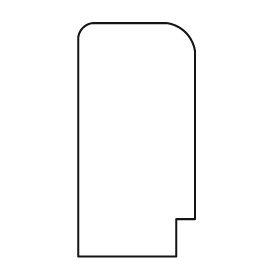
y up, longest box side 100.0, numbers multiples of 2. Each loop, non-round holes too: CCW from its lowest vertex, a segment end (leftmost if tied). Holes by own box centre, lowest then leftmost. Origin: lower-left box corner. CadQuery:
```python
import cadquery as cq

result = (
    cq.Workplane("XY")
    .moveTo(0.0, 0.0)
    .lineTo(42.0, 0.0)
    .lineTo(42.0, 16.0)
    .lineTo(50.0, 16.0)
    .lineTo(50.0, 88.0)
    .threePointArc((46.0, 96.0), (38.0, 100.0))
    .lineTo(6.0, 100.0)
    .threePointArc((2.0, 98.0), (0.0, 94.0))
    .close()
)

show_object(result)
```